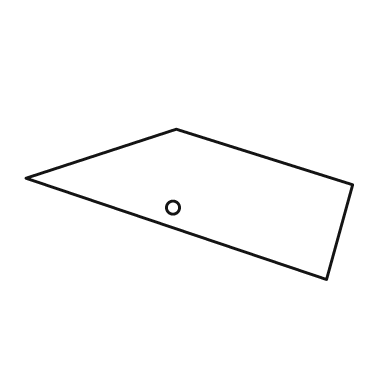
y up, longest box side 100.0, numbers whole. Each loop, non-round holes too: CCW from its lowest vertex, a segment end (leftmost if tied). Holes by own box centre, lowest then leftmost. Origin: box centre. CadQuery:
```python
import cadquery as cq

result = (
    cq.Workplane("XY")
    .moveTo(42.0, -23.0)
    .lineTo(50.0, 6.0)
    .lineTo(-4.0, 23.0)
    .lineTo(-50.0, 8.0)
    .close()
    .moveTo(-5.0, -1.0)
    .circle(2.0)
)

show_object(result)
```